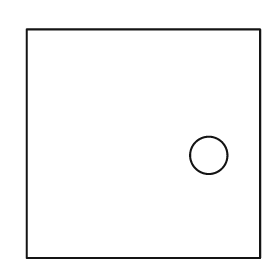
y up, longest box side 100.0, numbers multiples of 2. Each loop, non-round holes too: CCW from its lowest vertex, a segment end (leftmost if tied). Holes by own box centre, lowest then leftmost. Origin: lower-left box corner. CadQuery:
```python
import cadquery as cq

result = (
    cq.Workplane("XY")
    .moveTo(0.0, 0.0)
    .lineTo(100.0, 0.0)
    .lineTo(100.0, 98.0)
    .lineTo(0.0, 98.0)
    .close()
    .moveTo(78.0, 44.0)
    .circle(8.0)
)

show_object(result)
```